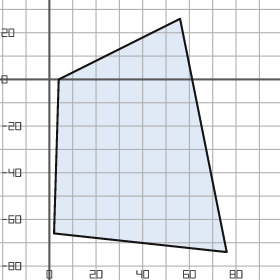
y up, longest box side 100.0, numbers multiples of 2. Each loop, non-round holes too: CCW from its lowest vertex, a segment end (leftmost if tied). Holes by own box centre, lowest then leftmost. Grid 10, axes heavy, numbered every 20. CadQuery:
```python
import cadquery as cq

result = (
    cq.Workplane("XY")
    .moveTo(76.0, -74.0)
    .lineTo(56.0, 26.0)
    .lineTo(4.0, 0.0)
    .lineTo(2.0, -66.0)
    .close()
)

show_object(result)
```